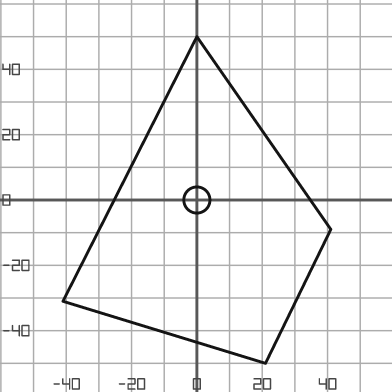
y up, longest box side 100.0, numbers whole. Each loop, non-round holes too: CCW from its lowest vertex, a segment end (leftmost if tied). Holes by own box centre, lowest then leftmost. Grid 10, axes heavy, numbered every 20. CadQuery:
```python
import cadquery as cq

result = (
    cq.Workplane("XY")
    .moveTo(21.0, -50.0)
    .lineTo(41.0, -9.0)
    .lineTo(0.0, 50.0)
    .lineTo(-41.0, -31.0)
    .close()
    .moveTo(0.0, 0.0)
    .circle(4.0)
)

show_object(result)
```